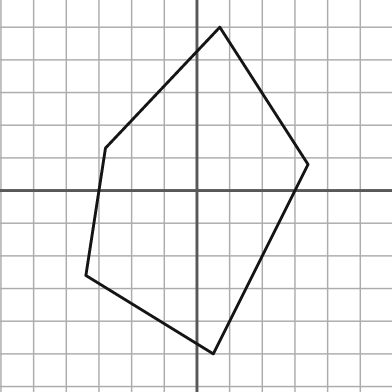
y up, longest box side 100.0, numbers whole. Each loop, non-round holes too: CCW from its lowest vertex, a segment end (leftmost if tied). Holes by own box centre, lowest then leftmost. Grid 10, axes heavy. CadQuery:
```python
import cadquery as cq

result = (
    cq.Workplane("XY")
    .moveTo(5.0, -50.0)
    .lineTo(34.0, 8.0)
    .lineTo(7.0, 50.0)
    .lineTo(-28.0, 13.0)
    .lineTo(-34.0, -26.0)
    .close()
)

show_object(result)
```